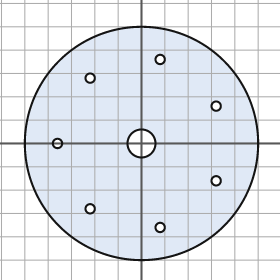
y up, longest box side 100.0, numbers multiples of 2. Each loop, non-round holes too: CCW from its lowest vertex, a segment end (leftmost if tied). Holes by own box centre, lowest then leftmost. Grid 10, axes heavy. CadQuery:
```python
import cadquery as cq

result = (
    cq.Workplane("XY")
    .moveTo(0.0, 0.0)
    .circle(50.0)
    .moveTo(8.0, -36.0)
    .circle(2.0)
    .moveTo(-22.0, -28.0)
    .circle(2.0)
    .moveTo(32.0, -16.0)
    .circle(2.0)
    .moveTo(-36.0, 0.0)
    .circle(2.0)
    .moveTo(0.0, 0.0)
    .circle(6.0)
    .moveTo(32.0, 16.0)
    .circle(2.0)
    .moveTo(-22.0, 28.0)
    .circle(2.0)
    .moveTo(8.0, 36.0)
    .circle(2.0)
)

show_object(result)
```